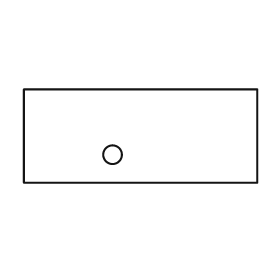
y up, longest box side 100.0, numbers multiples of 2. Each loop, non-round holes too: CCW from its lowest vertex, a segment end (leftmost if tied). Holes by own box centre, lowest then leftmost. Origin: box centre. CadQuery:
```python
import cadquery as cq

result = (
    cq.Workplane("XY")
    .moveTo(-50.0, -20.0)
    .lineTo(50.0, -20.0)
    .lineTo(50.0, 20.0)
    .lineTo(-50.0, 20.0)
    .close()
    .moveTo(-12.0, -8.0)
    .circle(4.0)
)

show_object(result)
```